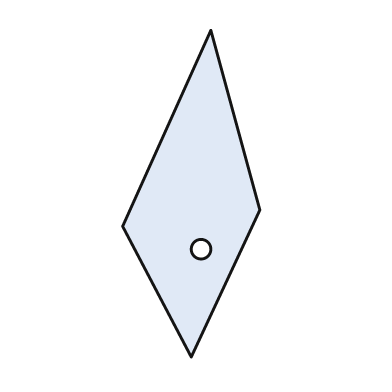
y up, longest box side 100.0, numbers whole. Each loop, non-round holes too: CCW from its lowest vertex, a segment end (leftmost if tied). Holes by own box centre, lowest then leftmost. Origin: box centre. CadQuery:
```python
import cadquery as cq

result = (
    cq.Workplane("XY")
    .moveTo(0.0, -50.0)
    .lineTo(21.0, -5.0)
    .lineTo(6.0, 50.0)
    .lineTo(-21.0, -10.0)
    .close()
    .moveTo(3.0, -17.0)
    .circle(3.0)
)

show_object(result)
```